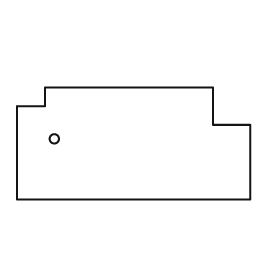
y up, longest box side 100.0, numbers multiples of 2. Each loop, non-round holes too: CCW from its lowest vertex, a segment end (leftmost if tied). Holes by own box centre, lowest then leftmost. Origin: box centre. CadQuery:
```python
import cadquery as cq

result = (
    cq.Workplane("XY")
    .moveTo(-50.0, -24.0)
    .lineTo(50.0, -24.0)
    .lineTo(50.0, 8.0)
    .lineTo(34.0, 8.0)
    .lineTo(34.0, 24.0)
    .lineTo(-38.0, 24.0)
    .lineTo(-38.0, 16.0)
    .lineTo(-50.0, 16.0)
    .close()
    .moveTo(-34.0, 2.0)
    .circle(2.0)
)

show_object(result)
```